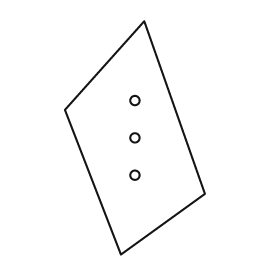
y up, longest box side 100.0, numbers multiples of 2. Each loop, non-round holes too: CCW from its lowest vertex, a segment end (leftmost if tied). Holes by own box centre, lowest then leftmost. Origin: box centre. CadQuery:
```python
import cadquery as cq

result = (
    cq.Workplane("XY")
    .moveTo(-6.0, -50.0)
    .lineTo(30.0, -24.0)
    .lineTo(4.0, 50.0)
    .lineTo(-30.0, 12.0)
    .close()
    .moveTo(0.0, -16.0)
    .circle(2.0)
    .moveTo(0.0, 0.0)
    .circle(2.0)
    .moveTo(0.0, 16.0)
    .circle(2.0)
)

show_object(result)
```